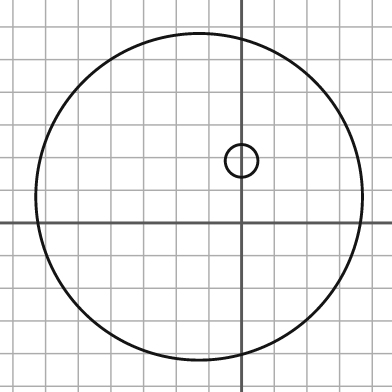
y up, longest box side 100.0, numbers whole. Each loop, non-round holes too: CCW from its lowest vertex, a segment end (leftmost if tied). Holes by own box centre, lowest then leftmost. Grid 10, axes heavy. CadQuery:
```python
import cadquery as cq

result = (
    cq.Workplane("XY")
    .moveTo(-13.0, 8.0)
    .circle(50.0)
    .moveTo(0.0, 19.0)
    .circle(5.0)
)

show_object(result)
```